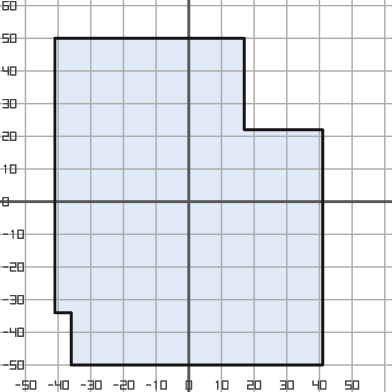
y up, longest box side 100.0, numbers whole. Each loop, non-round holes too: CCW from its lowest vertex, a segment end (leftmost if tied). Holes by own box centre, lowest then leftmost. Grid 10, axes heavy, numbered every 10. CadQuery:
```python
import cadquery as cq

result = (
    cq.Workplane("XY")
    .moveTo(-36.0, -50.0)
    .lineTo(41.0, -50.0)
    .lineTo(41.0, 22.0)
    .lineTo(17.0, 22.0)
    .lineTo(17.0, 50.0)
    .lineTo(-41.0, 50.0)
    .lineTo(-41.0, -34.0)
    .lineTo(-36.0, -34.0)
    .close()
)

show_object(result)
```